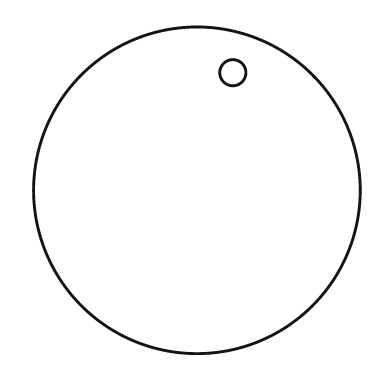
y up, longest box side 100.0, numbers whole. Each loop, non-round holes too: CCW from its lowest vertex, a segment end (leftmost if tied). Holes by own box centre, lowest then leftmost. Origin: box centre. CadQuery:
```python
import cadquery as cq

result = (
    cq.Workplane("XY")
    .moveTo(0.0, 0.0)
    .circle(50.0)
    .moveTo(11.0, 36.0)
    .circle(4.0)
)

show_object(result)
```